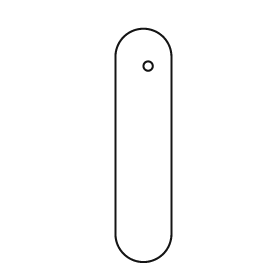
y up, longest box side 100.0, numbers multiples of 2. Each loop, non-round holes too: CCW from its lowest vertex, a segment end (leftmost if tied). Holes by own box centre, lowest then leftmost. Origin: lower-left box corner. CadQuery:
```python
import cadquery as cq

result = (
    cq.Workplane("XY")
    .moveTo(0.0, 12.0)
    .threePointArc((12.0, 0.0), (24.0, 12.0))
    .lineTo(24.0, 88.0)
    .threePointArc((12.0, 100.0), (0.0, 88.0))
    .close()
    .moveTo(14.0, 84.0)
    .circle(2.0)
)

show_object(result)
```